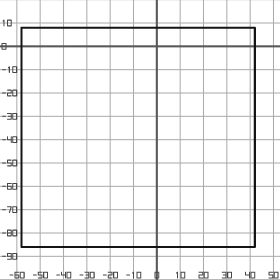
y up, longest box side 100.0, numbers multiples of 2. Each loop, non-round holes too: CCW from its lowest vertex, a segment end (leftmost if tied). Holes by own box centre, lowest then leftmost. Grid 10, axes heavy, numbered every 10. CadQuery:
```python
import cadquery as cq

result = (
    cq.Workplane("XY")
    .moveTo(-58.0, -86.0)
    .lineTo(42.0, -86.0)
    .lineTo(42.0, 8.0)
    .lineTo(-58.0, 8.0)
    .close()
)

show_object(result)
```